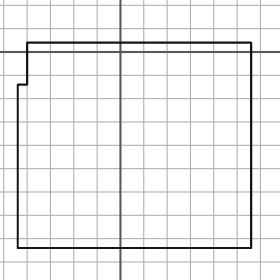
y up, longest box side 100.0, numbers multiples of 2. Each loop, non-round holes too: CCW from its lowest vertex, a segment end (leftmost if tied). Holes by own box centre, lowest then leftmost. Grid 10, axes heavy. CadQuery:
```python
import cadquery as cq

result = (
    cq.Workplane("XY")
    .moveTo(-44.0, -84.0)
    .lineTo(56.0, -84.0)
    .lineTo(56.0, 4.0)
    .lineTo(-40.0, 4.0)
    .lineTo(-40.0, -14.0)
    .lineTo(-44.0, -14.0)
    .close()
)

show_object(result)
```